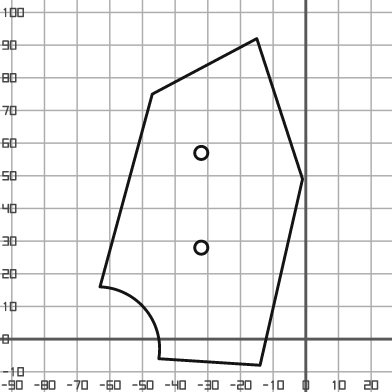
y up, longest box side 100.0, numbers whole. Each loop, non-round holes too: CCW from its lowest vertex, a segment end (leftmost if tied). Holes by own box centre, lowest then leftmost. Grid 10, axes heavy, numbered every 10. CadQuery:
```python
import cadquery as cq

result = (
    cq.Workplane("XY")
    .moveTo(-14.0, -8.0)
    .lineTo(-1.0, 49.0)
    .lineTo(-15.0, 92.0)
    .lineTo(-47.0, 75.0)
    .lineTo(-63.0, 16.0)
    .threePointArc((-49.0, 9.0), (-45.0, -6.0))
    .close()
    .moveTo(-32.0, 28.0)
    .circle(2.0)
    .moveTo(-32.0, 57.0)
    .circle(2.0)
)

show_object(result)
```